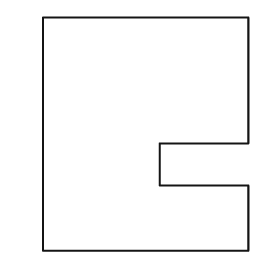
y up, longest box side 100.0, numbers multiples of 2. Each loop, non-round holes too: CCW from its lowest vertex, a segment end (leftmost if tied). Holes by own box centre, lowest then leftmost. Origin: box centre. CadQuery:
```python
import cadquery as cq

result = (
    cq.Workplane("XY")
    .moveTo(-44.0, -50.0)
    .lineTo(44.0, -50.0)
    .lineTo(44.0, -22.0)
    .lineTo(6.0, -22.0)
    .lineTo(6.0, -4.0)
    .lineTo(44.0, -4.0)
    .lineTo(44.0, 50.0)
    .lineTo(-44.0, 50.0)
    .close()
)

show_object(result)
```